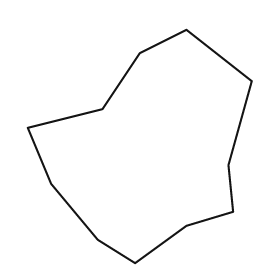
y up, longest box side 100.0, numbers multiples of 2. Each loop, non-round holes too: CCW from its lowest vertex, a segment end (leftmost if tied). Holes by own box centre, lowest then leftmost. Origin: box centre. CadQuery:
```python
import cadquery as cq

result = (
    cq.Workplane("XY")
    .moveTo(-2.0, -50.0)
    .lineTo(20.0, -34.0)
    .lineTo(40.0, -28.0)
    .lineTo(38.0, -8.0)
    .lineTo(48.0, 28.0)
    .lineTo(20.0, 50.0)
    .lineTo(0.0, 40.0)
    .lineTo(-16.0, 16.0)
    .lineTo(-48.0, 8.0)
    .lineTo(-38.0, -16.0)
    .lineTo(-18.0, -40.0)
    .close()
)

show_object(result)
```